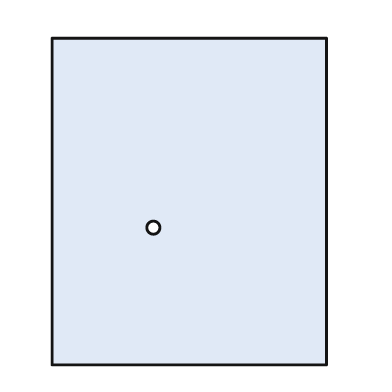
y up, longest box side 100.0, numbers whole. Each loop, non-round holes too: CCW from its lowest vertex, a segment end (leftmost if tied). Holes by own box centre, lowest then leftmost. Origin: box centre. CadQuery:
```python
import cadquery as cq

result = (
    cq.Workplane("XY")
    .moveTo(-42.0, -50.0)
    .lineTo(42.0, -50.0)
    .lineTo(42.0, 50.0)
    .lineTo(-42.0, 50.0)
    .close()
    .moveTo(-11.0, -8.0)
    .circle(2.0)
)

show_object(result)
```